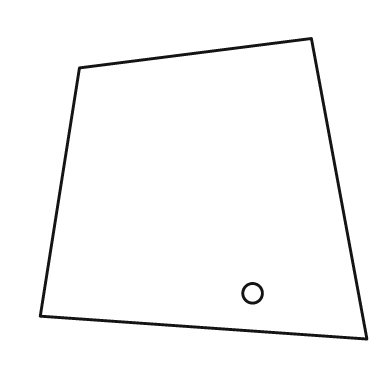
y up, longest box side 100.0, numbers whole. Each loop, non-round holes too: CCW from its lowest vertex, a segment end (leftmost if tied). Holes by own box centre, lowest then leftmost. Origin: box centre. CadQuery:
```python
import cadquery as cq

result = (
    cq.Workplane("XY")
    .moveTo(50.0, -46.0)
    .lineTo(33.0, 46.0)
    .lineTo(-38.0, 37.0)
    .lineTo(-50.0, -39.0)
    .close()
    .moveTo(15.0, -32.0)
    .circle(3.0)
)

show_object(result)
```